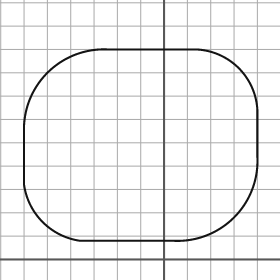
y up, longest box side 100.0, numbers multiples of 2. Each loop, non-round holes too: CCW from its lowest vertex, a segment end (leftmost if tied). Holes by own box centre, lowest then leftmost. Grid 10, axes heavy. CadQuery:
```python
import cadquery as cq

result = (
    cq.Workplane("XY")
    .moveTo(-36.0, 8.0)
    .lineTo(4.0, 8.0)
    .threePointArc((30.0, 18.0), (40.0, 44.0))
    .lineTo(40.0, 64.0)
    .threePointArc((32.0, 82.0), (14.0, 90.0))
    .lineTo(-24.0, 90.0)
    .threePointArc((-50.0, 80.0), (-60.0, 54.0))
    .lineTo(-60.0, 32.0)
    .threePointArc((-52.0, 16.0), (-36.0, 8.0))
    .close()
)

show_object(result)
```